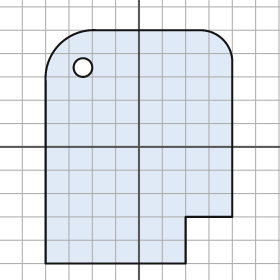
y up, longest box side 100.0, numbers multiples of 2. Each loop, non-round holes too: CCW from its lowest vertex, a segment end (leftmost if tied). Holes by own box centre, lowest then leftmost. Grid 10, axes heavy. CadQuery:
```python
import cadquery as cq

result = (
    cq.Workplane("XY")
    .moveTo(-40.0, -50.0)
    .lineTo(20.0, -50.0)
    .lineTo(20.0, -30.0)
    .lineTo(40.0, -30.0)
    .lineTo(40.0, 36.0)
    .threePointArc((36.0, 46.0), (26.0, 50.0))
    .lineTo(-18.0, 50.0)
    .threePointArc((-34.0, 44.0), (-40.0, 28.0))
    .close()
    .moveTo(-24.0, 34.0)
    .circle(4.0)
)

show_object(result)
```